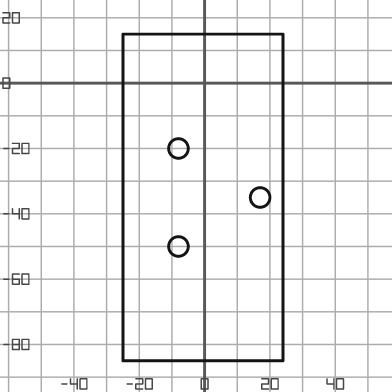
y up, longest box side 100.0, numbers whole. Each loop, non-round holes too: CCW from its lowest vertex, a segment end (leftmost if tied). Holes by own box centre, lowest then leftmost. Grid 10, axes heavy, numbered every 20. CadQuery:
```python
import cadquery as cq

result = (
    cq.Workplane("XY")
    .moveTo(-25.0, -85.0)
    .lineTo(24.0, -85.0)
    .lineTo(24.0, 15.0)
    .lineTo(-25.0, 15.0)
    .close()
    .moveTo(-8.0, -50.0)
    .circle(3.0)
    .moveTo(17.0, -35.0)
    .circle(3.0)
    .moveTo(-8.0, -20.0)
    .circle(3.0)
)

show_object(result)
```